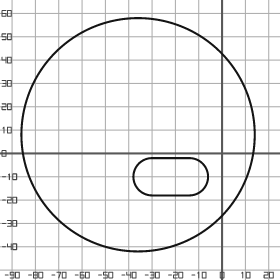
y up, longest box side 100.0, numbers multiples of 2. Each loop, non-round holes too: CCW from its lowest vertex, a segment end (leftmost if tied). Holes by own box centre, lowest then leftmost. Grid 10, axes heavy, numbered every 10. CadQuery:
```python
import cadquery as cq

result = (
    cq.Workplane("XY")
    .moveTo(-36.0, 8.0)
    .circle(50.0)
    .moveTo(-30.0, -18.0)
    .lineTo(-14.0, -18.0)
    .threePointArc((-6.0, -10.0), (-14.0, -2.0))
    .lineTo(-30.0, -2.0)
    .threePointArc((-38.0, -10.0), (-30.0, -18.0))
    .close()
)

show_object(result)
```